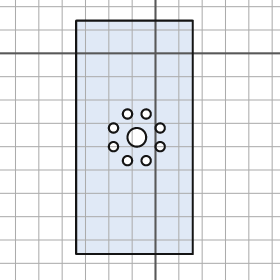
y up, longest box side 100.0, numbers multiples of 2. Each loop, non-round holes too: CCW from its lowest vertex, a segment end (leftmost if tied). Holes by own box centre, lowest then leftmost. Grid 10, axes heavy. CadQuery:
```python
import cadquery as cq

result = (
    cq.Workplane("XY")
    .moveTo(-34.0, -86.0)
    .lineTo(16.0, -86.0)
    .lineTo(16.0, 14.0)
    .lineTo(-34.0, 14.0)
    .close()
    .moveTo(-12.0, -46.0)
    .circle(2.0)
    .moveTo(-4.0, -46.0)
    .circle(2.0)
    .moveTo(-18.0, -40.0)
    .circle(2.0)
    .moveTo(2.0, -40.0)
    .circle(2.0)
    .moveTo(-8.0, -36.0)
    .circle(4.0)
    .moveTo(-18.0, -32.0)
    .circle(2.0)
    .moveTo(2.0, -32.0)
    .circle(2.0)
    .moveTo(-12.0, -26.0)
    .circle(2.0)
    .moveTo(-4.0, -26.0)
    .circle(2.0)
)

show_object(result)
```